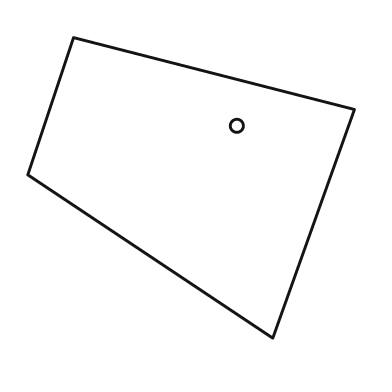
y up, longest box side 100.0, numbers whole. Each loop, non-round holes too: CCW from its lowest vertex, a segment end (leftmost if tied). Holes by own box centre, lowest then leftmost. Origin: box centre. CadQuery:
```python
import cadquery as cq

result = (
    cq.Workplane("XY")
    .moveTo(25.0, -46.0)
    .lineTo(50.0, 24.0)
    .lineTo(-36.0, 46.0)
    .lineTo(-50.0, 4.0)
    .close()
    .moveTo(14.0, 19.0)
    .circle(2.0)
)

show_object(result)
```